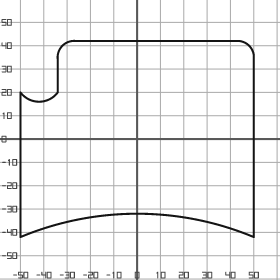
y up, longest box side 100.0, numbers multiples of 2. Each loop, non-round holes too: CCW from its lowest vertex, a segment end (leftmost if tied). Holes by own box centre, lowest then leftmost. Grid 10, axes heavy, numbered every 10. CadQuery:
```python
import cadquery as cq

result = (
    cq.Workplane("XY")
    .moveTo(-50.0, -42.0)
    .threePointArc((0.0, -32.0), (50.0, -42.0))
    .lineTo(50.0, 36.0)
    .threePointArc((48.0, 40.0), (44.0, 42.0))
    .lineTo(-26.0, 42.0)
    .threePointArc((-32.0, 40.0), (-34.0, 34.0))
    .lineTo(-34.0, 20.0)
    .threePointArc((-42.0, 16.0), (-50.0, 20.0))
    .close()
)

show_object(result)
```